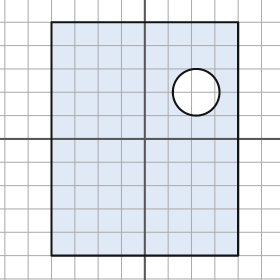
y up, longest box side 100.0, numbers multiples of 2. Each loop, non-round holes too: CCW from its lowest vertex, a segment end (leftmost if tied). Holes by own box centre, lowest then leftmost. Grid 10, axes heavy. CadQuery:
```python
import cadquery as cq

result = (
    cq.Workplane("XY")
    .moveTo(-40.0, -50.0)
    .lineTo(40.0, -50.0)
    .lineTo(40.0, 50.0)
    .lineTo(-40.0, 50.0)
    .close()
    .moveTo(22.0, 20.0)
    .circle(10.0)
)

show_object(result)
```